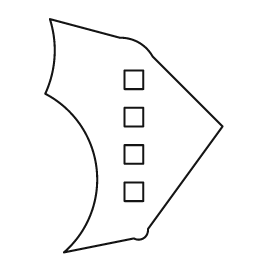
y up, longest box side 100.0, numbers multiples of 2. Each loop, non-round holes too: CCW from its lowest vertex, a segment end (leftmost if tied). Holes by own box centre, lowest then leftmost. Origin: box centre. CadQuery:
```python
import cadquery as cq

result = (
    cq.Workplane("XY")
    .moveTo(-30.0, -50.0)
    .lineTo(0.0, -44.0)
    .threePointArc((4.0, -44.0), (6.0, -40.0))
    .lineTo(38.0, 4.0)
    .lineTo(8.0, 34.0)
    .threePointArc((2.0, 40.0), (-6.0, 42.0))
    .lineTo(-36.0, 50.0)
    .threePointArc((-34.0, 34.0), (-38.0, 18.0))
    .threePointArc((-16.0, -14.0), (-30.0, -50.0))
    .close()
    .moveTo(-4.0, -28.0)
    .lineTo(4.0, -28.0)
    .lineTo(4.0, -20.0)
    .lineTo(-4.0, -20.0)
    .close()
    .moveTo(-4.0, -12.0)
    .lineTo(4.0, -12.0)
    .lineTo(4.0, -4.0)
    .lineTo(-4.0, -4.0)
    .close()
    .moveTo(-4.0, 4.0)
    .lineTo(4.0, 4.0)
    .lineTo(4.0, 12.0)
    .lineTo(-4.0, 12.0)
    .close()
    .moveTo(-4.0, 20.0)
    .lineTo(4.0, 20.0)
    .lineTo(4.0, 28.0)
    .lineTo(-4.0, 28.0)
    .close()
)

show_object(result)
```